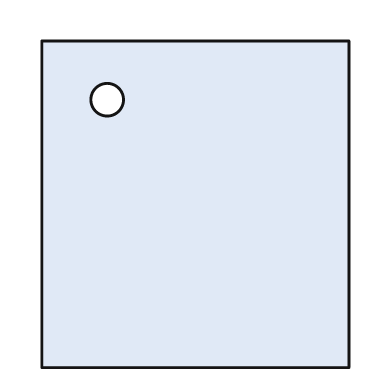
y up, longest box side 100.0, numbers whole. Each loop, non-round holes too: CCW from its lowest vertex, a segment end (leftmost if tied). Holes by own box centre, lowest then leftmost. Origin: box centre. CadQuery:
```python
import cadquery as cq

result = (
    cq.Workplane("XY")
    .moveTo(-47.0, -50.0)
    .lineTo(47.0, -50.0)
    .lineTo(47.0, 50.0)
    .lineTo(-47.0, 50.0)
    .close()
    .moveTo(-27.0, 32.0)
    .circle(5.0)
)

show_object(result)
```